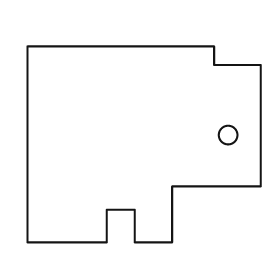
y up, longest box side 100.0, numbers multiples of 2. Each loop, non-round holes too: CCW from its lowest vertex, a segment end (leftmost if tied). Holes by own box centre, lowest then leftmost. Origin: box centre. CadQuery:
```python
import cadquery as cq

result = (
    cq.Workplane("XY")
    .moveTo(-50.0, -42.0)
    .lineTo(-16.0, -42.0)
    .lineTo(-16.0, -28.0)
    .lineTo(-4.0, -28.0)
    .lineTo(-4.0, -42.0)
    .lineTo(12.0, -42.0)
    .lineTo(12.0, -18.0)
    .lineTo(50.0, -18.0)
    .lineTo(50.0, 34.0)
    .lineTo(30.0, 34.0)
    .lineTo(30.0, 42.0)
    .lineTo(-50.0, 42.0)
    .close()
    .moveTo(36.0, 4.0)
    .circle(4.0)
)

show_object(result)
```